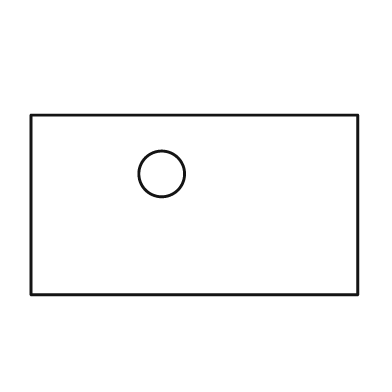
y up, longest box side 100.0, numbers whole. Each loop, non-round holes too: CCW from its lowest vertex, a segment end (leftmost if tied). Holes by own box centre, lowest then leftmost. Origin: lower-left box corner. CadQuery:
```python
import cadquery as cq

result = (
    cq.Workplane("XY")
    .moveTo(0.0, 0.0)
    .lineTo(100.0, 0.0)
    .lineTo(100.0, 55.0)
    .lineTo(0.0, 55.0)
    .close()
    .moveTo(40.0, 37.0)
    .circle(7.0)
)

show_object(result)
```